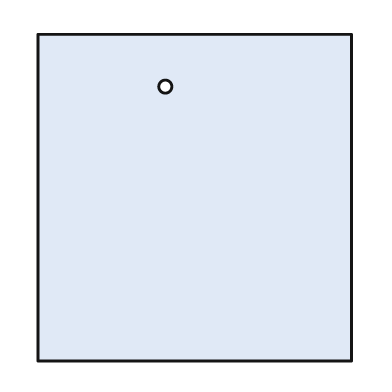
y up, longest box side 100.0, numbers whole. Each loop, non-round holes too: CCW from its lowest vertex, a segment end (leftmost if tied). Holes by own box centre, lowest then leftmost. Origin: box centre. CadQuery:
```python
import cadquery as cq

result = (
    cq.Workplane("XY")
    .moveTo(-48.0, -50.0)
    .lineTo(48.0, -50.0)
    .lineTo(48.0, 50.0)
    .lineTo(-48.0, 50.0)
    .close()
    .moveTo(-9.0, 34.0)
    .circle(2.0)
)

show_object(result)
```